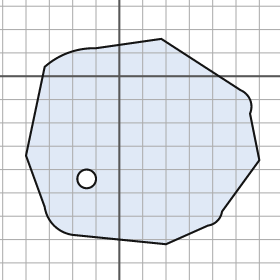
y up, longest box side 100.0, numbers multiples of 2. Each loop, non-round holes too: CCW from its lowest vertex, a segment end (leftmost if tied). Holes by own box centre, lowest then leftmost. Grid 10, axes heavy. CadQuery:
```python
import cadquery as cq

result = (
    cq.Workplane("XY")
    .moveTo(20.0, -72.0)
    .lineTo(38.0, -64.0)
    .threePointArc((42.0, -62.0), (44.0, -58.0))
    .lineTo(60.0, -36.0)
    .lineTo(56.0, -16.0)
    .threePointArc((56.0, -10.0), (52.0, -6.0))
    .lineTo(18.0, 16.0)
    .lineTo(-10.0, 12.0)
    .threePointArc((-22.0, 10.0), (-32.0, 4.0))
    .lineTo(-40.0, -34.0)
    .lineTo(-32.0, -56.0)
    .threePointArc((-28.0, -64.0), (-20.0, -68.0))
    .close()
    .moveTo(-14.0, -44.0)
    .circle(4.0)
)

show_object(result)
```